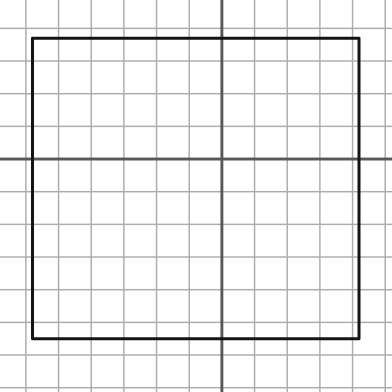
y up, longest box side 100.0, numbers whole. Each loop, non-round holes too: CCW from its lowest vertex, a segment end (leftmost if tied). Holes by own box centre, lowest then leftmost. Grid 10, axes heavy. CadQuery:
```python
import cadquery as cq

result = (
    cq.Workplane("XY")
    .moveTo(-58.0, -55.0)
    .lineTo(42.0, -55.0)
    .lineTo(42.0, 37.0)
    .lineTo(-58.0, 37.0)
    .close()
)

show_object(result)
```